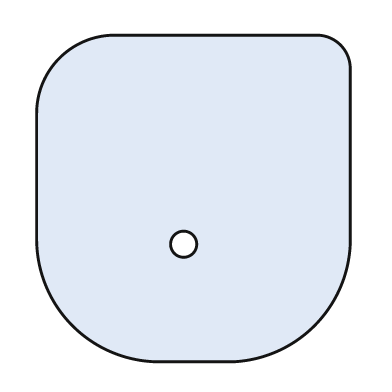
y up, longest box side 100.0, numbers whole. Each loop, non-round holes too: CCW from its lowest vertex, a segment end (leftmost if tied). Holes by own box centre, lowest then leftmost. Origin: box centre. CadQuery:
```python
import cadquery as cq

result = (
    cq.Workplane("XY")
    .moveTo(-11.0, -50.0)
    .lineTo(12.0, -50.0)
    .threePointArc((37.0, -39.0), (48.0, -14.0))
    .lineTo(48.0, 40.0)
    .threePointArc((45.0, 47.0), (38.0, 50.0))
    .lineTo(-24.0, 50.0)
    .threePointArc((-41.0, 43.0), (-48.0, 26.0))
    .lineTo(-48.0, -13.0)
    .threePointArc((-37.0, -39.0), (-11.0, -50.0))
    .close()
    .moveTo(-3.0, -14.0)
    .circle(4.0)
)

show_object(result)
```